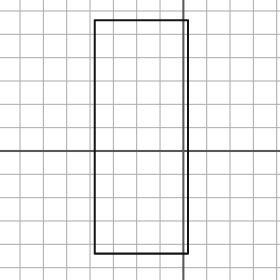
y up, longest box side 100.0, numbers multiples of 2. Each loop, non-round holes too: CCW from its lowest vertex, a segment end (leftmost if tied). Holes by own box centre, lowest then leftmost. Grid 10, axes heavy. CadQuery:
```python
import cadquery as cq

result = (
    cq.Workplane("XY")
    .moveTo(-38.0, -44.0)
    .lineTo(2.0, -44.0)
    .lineTo(2.0, 56.0)
    .lineTo(-38.0, 56.0)
    .close()
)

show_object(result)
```